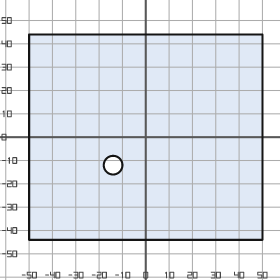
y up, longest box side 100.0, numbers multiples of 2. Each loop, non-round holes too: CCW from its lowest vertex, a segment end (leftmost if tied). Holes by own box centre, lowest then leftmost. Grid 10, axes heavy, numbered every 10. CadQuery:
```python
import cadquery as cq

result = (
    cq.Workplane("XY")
    .moveTo(-50.0, -44.0)
    .lineTo(50.0, -44.0)
    .lineTo(50.0, 44.0)
    .lineTo(-50.0, 44.0)
    .close()
    .moveTo(-14.0, -12.0)
    .circle(4.0)
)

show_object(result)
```